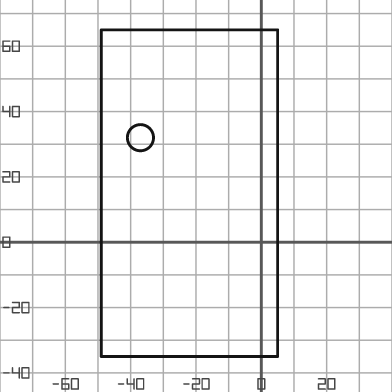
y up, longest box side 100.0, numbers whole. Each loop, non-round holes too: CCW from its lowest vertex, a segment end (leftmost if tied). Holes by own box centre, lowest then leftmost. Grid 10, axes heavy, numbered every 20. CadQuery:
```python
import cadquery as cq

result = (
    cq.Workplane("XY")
    .moveTo(-49.0, -35.0)
    .lineTo(5.0, -35.0)
    .lineTo(5.0, 65.0)
    .lineTo(-49.0, 65.0)
    .close()
    .moveTo(-37.0, 32.0)
    .circle(4.0)
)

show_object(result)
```